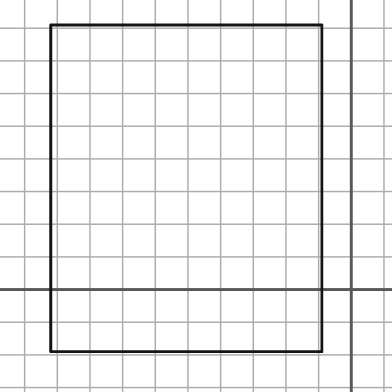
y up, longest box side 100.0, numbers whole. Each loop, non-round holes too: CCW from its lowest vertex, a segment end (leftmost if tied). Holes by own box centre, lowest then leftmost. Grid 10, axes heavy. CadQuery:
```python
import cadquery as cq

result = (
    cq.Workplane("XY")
    .moveTo(-92.0, -19.0)
    .lineTo(-9.0, -19.0)
    .lineTo(-9.0, 81.0)
    .lineTo(-92.0, 81.0)
    .close()
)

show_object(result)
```